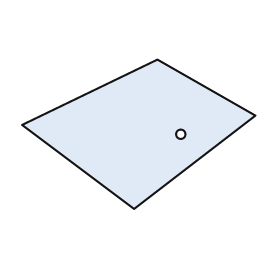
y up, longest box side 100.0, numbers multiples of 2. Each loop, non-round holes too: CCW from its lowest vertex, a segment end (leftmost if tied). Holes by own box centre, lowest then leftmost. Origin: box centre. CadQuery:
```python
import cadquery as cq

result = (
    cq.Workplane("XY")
    .moveTo(-2.0, -32.0)
    .lineTo(50.0, 8.0)
    .lineTo(8.0, 32.0)
    .lineTo(-50.0, 4.0)
    .close()
    .moveTo(18.0, 0.0)
    .circle(2.0)
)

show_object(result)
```